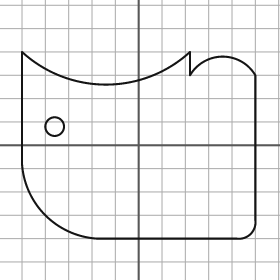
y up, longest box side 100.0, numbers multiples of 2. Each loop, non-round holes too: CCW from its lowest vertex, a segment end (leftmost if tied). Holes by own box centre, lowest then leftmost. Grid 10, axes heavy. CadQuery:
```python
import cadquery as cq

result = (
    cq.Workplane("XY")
    .moveTo(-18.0, -40.0)
    .lineTo(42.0, -40.0)
    .threePointArc((48.0, -38.0), (50.0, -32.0))
    .lineTo(50.0, 30.0)
    .threePointArc((36.0, 38.0), (22.0, 30.0))
    .lineTo(22.0, 40.0)
    .threePointArc((-14.0, 26.0), (-50.0, 40.0))
    .lineTo(-50.0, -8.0)
    .threePointArc((-40.0, -30.0), (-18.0, -40.0))
    .close()
    .moveTo(-36.0, 8.0)
    .circle(4.0)
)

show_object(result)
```